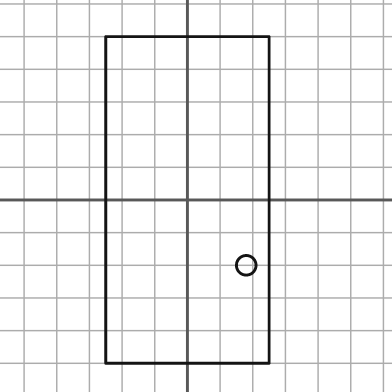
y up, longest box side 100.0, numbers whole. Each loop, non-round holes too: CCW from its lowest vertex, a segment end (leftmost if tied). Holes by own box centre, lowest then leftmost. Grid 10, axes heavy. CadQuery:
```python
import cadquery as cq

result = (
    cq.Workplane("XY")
    .moveTo(-25.0, -50.0)
    .lineTo(25.0, -50.0)
    .lineTo(25.0, 50.0)
    .lineTo(-25.0, 50.0)
    .close()
    .moveTo(18.0, -20.0)
    .circle(3.0)
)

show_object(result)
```